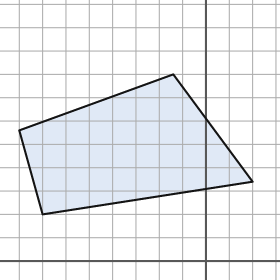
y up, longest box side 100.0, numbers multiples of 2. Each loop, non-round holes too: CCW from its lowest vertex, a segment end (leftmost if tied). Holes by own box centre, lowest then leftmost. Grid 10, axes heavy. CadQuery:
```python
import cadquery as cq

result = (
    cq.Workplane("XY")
    .moveTo(-70.0, 20.0)
    .lineTo(20.0, 34.0)
    .lineTo(-14.0, 80.0)
    .lineTo(-80.0, 56.0)
    .close()
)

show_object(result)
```